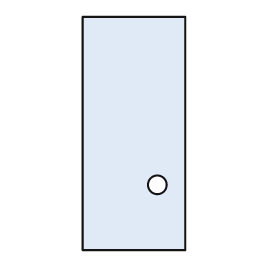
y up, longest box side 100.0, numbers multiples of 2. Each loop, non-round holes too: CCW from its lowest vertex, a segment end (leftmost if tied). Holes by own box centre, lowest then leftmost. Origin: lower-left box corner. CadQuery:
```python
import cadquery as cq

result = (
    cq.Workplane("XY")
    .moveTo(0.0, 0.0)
    .lineTo(44.0, 0.0)
    .lineTo(44.0, 100.0)
    .lineTo(0.0, 100.0)
    .close()
    .moveTo(32.0, 28.0)
    .circle(4.0)
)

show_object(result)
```